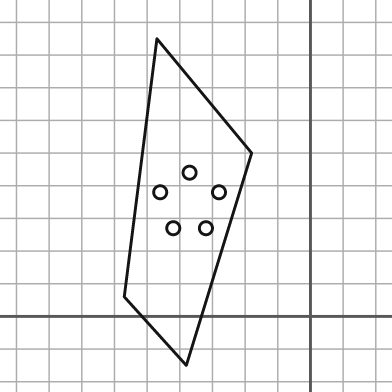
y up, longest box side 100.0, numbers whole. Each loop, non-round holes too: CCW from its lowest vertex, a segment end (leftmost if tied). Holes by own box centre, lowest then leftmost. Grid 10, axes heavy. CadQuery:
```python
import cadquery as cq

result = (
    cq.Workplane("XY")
    .moveTo(-38.0, -15.0)
    .lineTo(-18.0, 50.0)
    .lineTo(-47.0, 85.0)
    .lineTo(-57.0, 6.0)
    .close()
    .moveTo(-42.0, 27.0)
    .circle(2.0)
    .moveTo(-32.0, 27.0)
    .circle(2.0)
    .moveTo(-46.0, 38.0)
    .circle(2.0)
    .moveTo(-28.0, 38.0)
    .circle(2.0)
    .moveTo(-37.0, 44.0)
    .circle(2.0)
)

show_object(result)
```